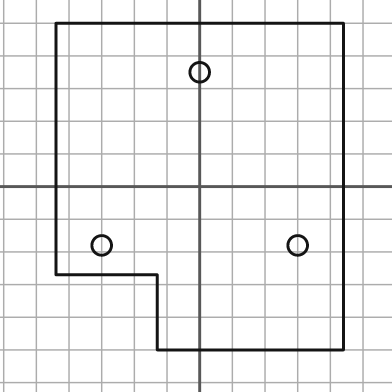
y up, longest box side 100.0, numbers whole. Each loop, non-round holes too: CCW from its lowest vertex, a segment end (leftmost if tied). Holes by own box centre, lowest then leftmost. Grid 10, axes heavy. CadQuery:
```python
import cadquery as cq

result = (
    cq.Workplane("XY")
    .moveTo(-13.0, -50.0)
    .lineTo(44.0, -50.0)
    .lineTo(44.0, 50.0)
    .lineTo(-44.0, 50.0)
    .lineTo(-44.0, -27.0)
    .lineTo(-13.0, -27.0)
    .close()
    .moveTo(-30.0, -18.0)
    .circle(3.0)
    .moveTo(30.0, -18.0)
    .circle(3.0)
    .moveTo(0.0, 35.0)
    .circle(3.0)
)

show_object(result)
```